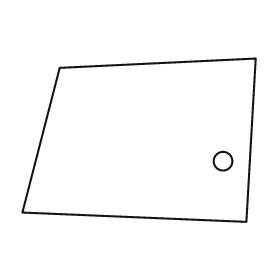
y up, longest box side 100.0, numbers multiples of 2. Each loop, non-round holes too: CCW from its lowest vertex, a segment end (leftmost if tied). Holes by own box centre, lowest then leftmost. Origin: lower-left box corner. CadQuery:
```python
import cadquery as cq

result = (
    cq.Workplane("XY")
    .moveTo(96.0, 0.0)
    .lineTo(100.0, 70.0)
    .lineTo(16.0, 66.0)
    .lineTo(0.0, 4.0)
    .close()
    .moveTo(86.0, 26.0)
    .circle(4.0)
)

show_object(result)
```